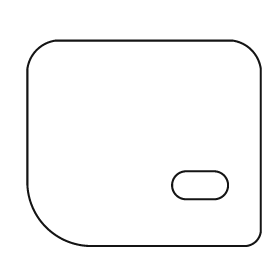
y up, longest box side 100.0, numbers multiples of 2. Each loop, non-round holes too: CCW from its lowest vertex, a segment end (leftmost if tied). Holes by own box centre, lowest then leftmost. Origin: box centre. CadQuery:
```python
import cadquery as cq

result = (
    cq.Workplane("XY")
    .moveTo(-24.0, -44.0)
    .lineTo(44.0, -44.0)
    .threePointArc((48.0, -42.0), (50.0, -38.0))
    .lineTo(50.0, 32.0)
    .threePointArc((46.0, 40.0), (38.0, 44.0))
    .lineTo(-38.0, 44.0)
    .threePointArc((-46.0, 40.0), (-50.0, 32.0))
    .lineTo(-50.0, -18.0)
    .threePointArc((-42.0, -36.0), (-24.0, -44.0))
    .close()
    .moveTo(18.0, -24.0)
    .lineTo(30.0, -24.0)
    .threePointArc((36.0, -18.0), (30.0, -12.0))
    .lineTo(18.0, -12.0)
    .threePointArc((12.0, -18.0), (18.0, -24.0))
    .close()
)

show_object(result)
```